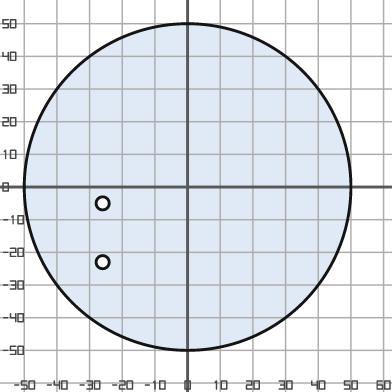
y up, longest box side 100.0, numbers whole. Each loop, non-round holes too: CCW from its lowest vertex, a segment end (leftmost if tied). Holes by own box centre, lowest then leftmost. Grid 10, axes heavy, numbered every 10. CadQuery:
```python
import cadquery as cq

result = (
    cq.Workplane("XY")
    .moveTo(0.0, 0.0)
    .circle(50.0)
    .moveTo(-26.0, -23.0)
    .circle(2.0)
    .moveTo(-26.0, -5.0)
    .circle(2.0)
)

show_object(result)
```